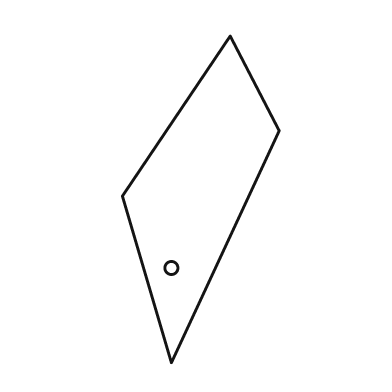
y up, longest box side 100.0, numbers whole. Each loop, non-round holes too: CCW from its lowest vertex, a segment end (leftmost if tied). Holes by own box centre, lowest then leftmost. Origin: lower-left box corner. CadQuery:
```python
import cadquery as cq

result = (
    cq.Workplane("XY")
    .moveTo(15.0, 0.0)
    .lineTo(48.0, 71.0)
    .lineTo(33.0, 100.0)
    .lineTo(0.0, 51.0)
    .close()
    .moveTo(15.0, 29.0)
    .circle(2.0)
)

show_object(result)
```